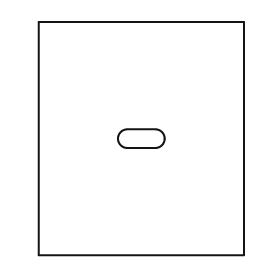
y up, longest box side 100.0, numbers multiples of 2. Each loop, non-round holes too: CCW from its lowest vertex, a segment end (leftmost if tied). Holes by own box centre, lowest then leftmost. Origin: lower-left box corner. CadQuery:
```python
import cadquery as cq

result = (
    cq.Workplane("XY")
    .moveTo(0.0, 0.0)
    .lineTo(88.0, 0.0)
    .lineTo(88.0, 100.0)
    .lineTo(0.0, 100.0)
    .close()
    .moveTo(38.0, 46.0)
    .lineTo(50.0, 46.0)
    .threePointArc((54.0, 50.0), (50.0, 54.0))
    .lineTo(38.0, 54.0)
    .threePointArc((34.0, 50.0), (38.0, 46.0))
    .close()
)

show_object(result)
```